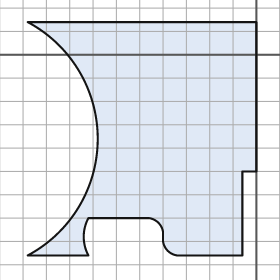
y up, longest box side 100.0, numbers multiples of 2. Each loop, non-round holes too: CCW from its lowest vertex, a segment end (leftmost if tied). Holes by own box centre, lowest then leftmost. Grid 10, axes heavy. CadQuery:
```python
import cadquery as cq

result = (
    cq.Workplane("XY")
    .moveTo(-98.0, -86.0)
    .lineTo(-72.0, -86.0)
    .threePointArc((-74.0, -78.0), (-72.0, -70.0))
    .lineTo(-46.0, -70.0)
    .threePointArc((-42.0, -72.0), (-40.0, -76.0))
    .lineTo(-40.0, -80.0)
    .threePointArc((-38.0, -84.0), (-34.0, -86.0))
    .lineTo(-6.0, -86.0)
    .lineTo(-6.0, -50.0)
    .lineTo(0.0, -50.0)
    .lineTo(0.0, 14.0)
    .lineTo(-98.0, 14.0)
    .threePointArc((-68.0, -36.0), (-98.0, -86.0))
    .close()
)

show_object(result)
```